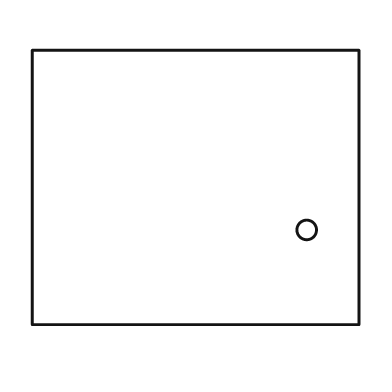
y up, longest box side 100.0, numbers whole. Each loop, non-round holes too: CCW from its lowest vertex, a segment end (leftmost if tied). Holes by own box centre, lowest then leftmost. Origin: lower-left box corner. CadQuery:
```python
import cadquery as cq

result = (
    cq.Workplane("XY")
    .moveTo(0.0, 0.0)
    .lineTo(100.0, 0.0)
    .lineTo(100.0, 84.0)
    .lineTo(0.0, 84.0)
    .close()
    .moveTo(84.0, 29.0)
    .circle(3.0)
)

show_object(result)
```